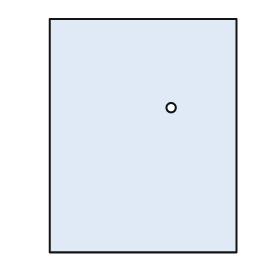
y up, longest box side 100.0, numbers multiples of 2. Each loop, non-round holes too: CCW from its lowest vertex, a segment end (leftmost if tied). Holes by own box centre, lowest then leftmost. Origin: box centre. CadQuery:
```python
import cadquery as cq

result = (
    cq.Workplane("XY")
    .moveTo(-40.0, -50.0)
    .lineTo(40.0, -50.0)
    .lineTo(40.0, 50.0)
    .lineTo(-40.0, 50.0)
    .close()
    .moveTo(12.0, 12.0)
    .circle(2.0)
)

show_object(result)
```